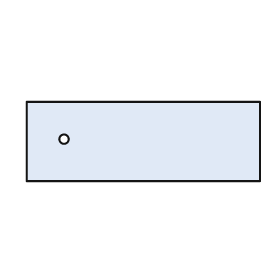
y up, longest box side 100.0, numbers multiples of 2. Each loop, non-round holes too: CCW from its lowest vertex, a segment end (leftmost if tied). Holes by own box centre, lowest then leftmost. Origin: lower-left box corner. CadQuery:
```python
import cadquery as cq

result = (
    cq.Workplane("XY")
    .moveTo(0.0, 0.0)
    .lineTo(100.0, 0.0)
    .lineTo(100.0, 34.0)
    .lineTo(0.0, 34.0)
    .close()
    .moveTo(16.0, 18.0)
    .circle(2.0)
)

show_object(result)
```